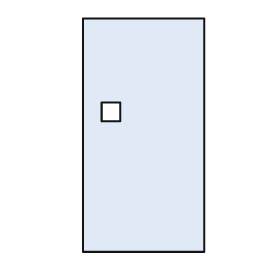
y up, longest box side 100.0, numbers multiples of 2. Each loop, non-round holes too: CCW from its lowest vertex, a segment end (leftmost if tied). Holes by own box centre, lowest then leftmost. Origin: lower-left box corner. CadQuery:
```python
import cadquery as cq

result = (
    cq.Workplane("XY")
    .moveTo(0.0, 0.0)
    .lineTo(52.0, 0.0)
    .lineTo(52.0, 100.0)
    .lineTo(0.0, 100.0)
    .close()
    .moveTo(8.0, 56.0)
    .lineTo(16.0, 56.0)
    .lineTo(16.0, 64.0)
    .lineTo(8.0, 64.0)
    .close()
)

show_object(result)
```